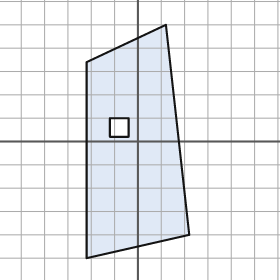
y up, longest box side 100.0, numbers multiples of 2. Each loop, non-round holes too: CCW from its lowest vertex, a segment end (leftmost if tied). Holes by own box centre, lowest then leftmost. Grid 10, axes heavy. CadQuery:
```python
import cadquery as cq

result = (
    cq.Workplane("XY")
    .moveTo(-22.0, -50.0)
    .lineTo(22.0, -40.0)
    .lineTo(12.0, 50.0)
    .lineTo(-22.0, 34.0)
    .close()
    .moveTo(-12.0, 2.0)
    .lineTo(-4.0, 2.0)
    .lineTo(-4.0, 10.0)
    .lineTo(-12.0, 10.0)
    .close()
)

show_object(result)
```